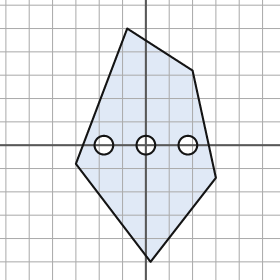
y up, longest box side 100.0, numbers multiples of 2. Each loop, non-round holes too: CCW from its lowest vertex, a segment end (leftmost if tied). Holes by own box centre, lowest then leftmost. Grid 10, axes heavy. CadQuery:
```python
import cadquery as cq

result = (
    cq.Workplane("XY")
    .moveTo(2.0, -50.0)
    .lineTo(30.0, -14.0)
    .lineTo(20.0, 32.0)
    .lineTo(-8.0, 50.0)
    .lineTo(-30.0, -8.0)
    .close()
    .moveTo(-18.0, 0.0)
    .circle(4.0)
    .moveTo(0.0, 0.0)
    .circle(4.0)
    .moveTo(18.0, 0.0)
    .circle(4.0)
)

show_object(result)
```